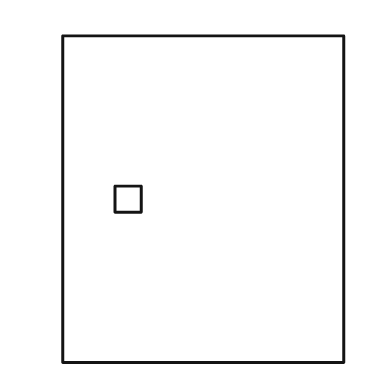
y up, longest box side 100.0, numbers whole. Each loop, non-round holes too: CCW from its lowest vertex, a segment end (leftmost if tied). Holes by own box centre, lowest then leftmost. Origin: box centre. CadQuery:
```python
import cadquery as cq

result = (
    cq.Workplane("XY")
    .moveTo(-43.0, -50.0)
    .lineTo(43.0, -50.0)
    .lineTo(43.0, 50.0)
    .lineTo(-43.0, 50.0)
    .close()
    .moveTo(-27.0, -4.0)
    .lineTo(-19.0, -4.0)
    .lineTo(-19.0, 4.0)
    .lineTo(-27.0, 4.0)
    .close()
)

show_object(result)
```